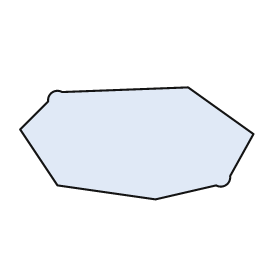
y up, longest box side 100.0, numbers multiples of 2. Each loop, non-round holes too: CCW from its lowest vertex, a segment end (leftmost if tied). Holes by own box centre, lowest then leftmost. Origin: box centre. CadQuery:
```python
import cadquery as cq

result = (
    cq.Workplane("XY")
    .moveTo(8.0, -24.0)
    .lineTo(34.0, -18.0)
    .threePointArc((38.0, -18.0), (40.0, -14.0))
    .lineTo(50.0, 4.0)
    .lineTo(22.0, 24.0)
    .lineTo(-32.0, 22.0)
    .threePointArc((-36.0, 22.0), (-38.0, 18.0))
    .lineTo(-50.0, 6.0)
    .lineTo(-34.0, -18.0)
    .close()
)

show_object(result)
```